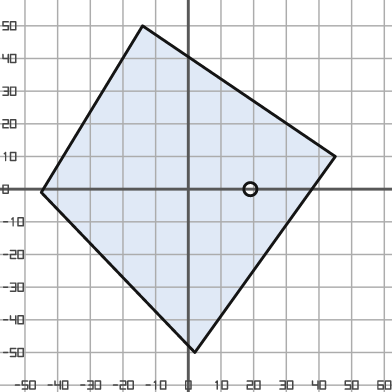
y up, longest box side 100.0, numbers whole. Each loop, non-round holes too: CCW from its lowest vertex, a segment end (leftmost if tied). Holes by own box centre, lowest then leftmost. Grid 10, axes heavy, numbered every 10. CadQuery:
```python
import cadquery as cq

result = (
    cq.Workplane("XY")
    .moveTo(2.0, -50.0)
    .lineTo(45.0, 10.0)
    .lineTo(-14.0, 50.0)
    .lineTo(-45.0, -1.0)
    .close()
    .moveTo(19.0, 0.0)
    .circle(2.0)
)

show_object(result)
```